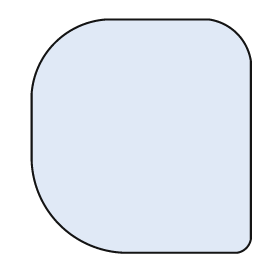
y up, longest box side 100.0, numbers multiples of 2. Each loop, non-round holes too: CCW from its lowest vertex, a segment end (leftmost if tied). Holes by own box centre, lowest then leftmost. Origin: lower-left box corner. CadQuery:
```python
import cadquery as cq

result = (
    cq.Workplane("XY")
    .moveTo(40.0, 0.0)
    .lineTo(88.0, 0.0)
    .threePointArc((92.0, 2.0), (94.0, 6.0))
    .lineTo(94.0, 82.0)
    .threePointArc((88.0, 94.0), (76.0, 100.0))
    .lineTo(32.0, 100.0)
    .threePointArc((10.0, 90.0), (0.0, 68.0))
    .lineTo(0.0, 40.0)
    .threePointArc((12.0, 12.0), (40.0, 0.0))
    .close()
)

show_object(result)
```